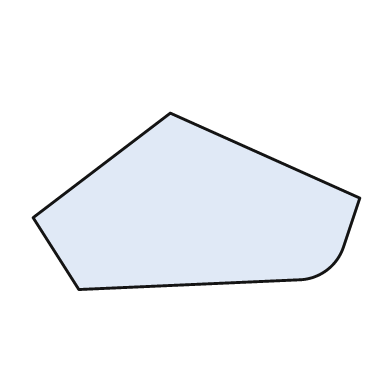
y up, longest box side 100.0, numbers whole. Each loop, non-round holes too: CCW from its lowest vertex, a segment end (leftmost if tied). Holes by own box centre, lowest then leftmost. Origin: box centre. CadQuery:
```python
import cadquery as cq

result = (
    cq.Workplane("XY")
    .moveTo(-36.0, -27.0)
    .lineTo(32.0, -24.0)
    .threePointArc((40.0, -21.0), (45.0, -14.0))
    .lineTo(50.0, 1.0)
    .lineTo(-8.0, 27.0)
    .lineTo(-50.0, -5.0)
    .close()
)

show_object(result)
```